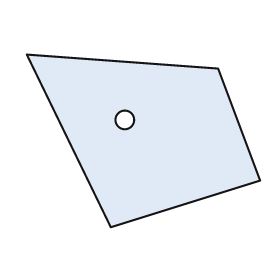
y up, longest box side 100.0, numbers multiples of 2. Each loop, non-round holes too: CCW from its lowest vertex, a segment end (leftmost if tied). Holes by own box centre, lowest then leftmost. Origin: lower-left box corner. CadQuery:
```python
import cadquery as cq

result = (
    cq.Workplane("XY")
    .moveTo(36.0, 0.0)
    .lineTo(100.0, 20.0)
    .lineTo(82.0, 68.0)
    .lineTo(0.0, 74.0)
    .close()
    .moveTo(42.0, 46.0)
    .circle(4.0)
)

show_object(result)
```